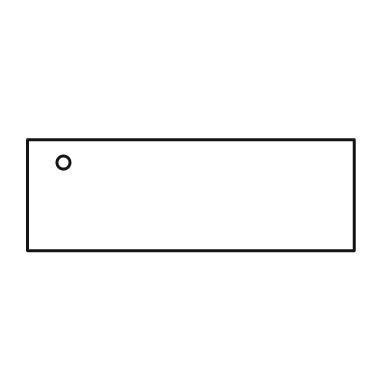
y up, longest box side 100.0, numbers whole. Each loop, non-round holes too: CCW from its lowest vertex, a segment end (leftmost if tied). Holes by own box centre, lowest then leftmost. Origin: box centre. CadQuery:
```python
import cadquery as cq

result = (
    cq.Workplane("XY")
    .moveTo(-50.0, -17.0)
    .lineTo(50.0, -17.0)
    .lineTo(50.0, 17.0)
    .lineTo(-50.0, 17.0)
    .close()
    .moveTo(-39.0, 10.0)
    .circle(2.0)
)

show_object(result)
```